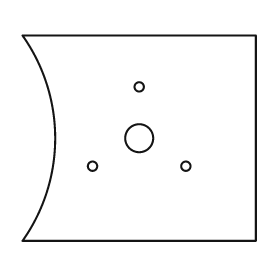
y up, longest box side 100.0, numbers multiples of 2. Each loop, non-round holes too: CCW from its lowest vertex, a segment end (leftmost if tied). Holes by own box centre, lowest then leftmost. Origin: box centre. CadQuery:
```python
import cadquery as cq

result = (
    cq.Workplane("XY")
    .moveTo(-50.0, -44.0)
    .lineTo(50.0, -44.0)
    .lineTo(50.0, 44.0)
    .lineTo(-50.0, 44.0)
    .threePointArc((-36.0, 0.0), (-50.0, -44.0))
    .close()
    .moveTo(-20.0, -12.0)
    .circle(2.0)
    .moveTo(20.0, -12.0)
    .circle(2.0)
    .moveTo(0.0, 0.0)
    .circle(6.0)
    .moveTo(0.0, 22.0)
    .circle(2.0)
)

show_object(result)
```